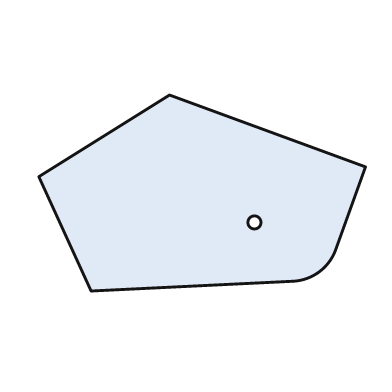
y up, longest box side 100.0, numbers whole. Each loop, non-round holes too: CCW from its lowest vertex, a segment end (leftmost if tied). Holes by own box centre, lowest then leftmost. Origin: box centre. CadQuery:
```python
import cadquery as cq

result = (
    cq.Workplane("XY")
    .moveTo(-34.0, -30.0)
    .lineTo(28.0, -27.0)
    .threePointArc((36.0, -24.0), (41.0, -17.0))
    .lineTo(50.0, 8.0)
    .lineTo(-10.0, 30.0)
    .lineTo(-50.0, 5.0)
    .close()
    .moveTo(16.0, -9.0)
    .circle(2.0)
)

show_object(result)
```